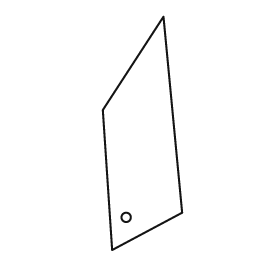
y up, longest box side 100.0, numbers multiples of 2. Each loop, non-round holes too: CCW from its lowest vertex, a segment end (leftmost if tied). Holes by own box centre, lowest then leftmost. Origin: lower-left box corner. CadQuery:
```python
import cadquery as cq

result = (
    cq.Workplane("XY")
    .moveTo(4.0, 0.0)
    .lineTo(34.0, 16.0)
    .lineTo(26.0, 100.0)
    .lineTo(0.0, 60.0)
    .close()
    .moveTo(10.0, 14.0)
    .circle(2.0)
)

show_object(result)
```